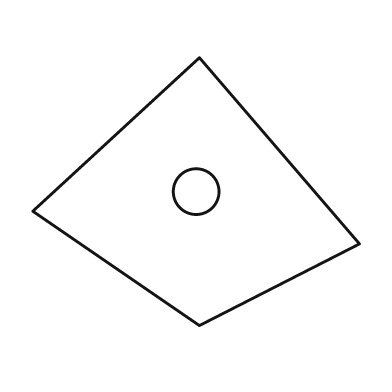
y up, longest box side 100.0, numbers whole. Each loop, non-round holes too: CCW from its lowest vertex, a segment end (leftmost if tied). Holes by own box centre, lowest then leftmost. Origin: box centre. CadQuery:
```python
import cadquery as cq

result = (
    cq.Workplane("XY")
    .moveTo(1.0, -41.0)
    .lineTo(50.0, -16.0)
    .lineTo(1.0, 41.0)
    .lineTo(-50.0, -6.0)
    .close()
    .moveTo(0.0, 0.0)
    .circle(7.0)
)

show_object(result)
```